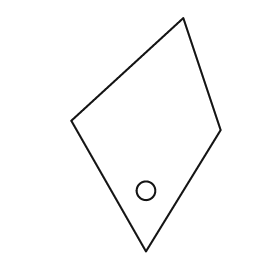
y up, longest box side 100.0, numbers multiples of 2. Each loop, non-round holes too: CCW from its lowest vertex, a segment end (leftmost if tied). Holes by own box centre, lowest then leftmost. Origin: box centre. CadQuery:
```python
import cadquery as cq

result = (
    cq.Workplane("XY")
    .moveTo(0.0, -50.0)
    .lineTo(32.0, 2.0)
    .lineTo(16.0, 50.0)
    .lineTo(-32.0, 6.0)
    .close()
    .moveTo(0.0, -24.0)
    .circle(4.0)
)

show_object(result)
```